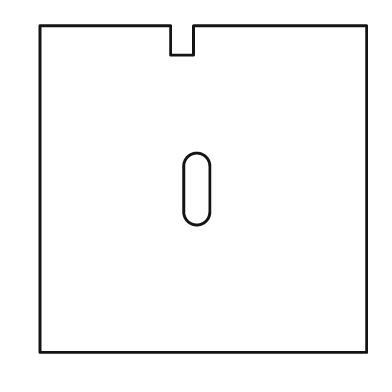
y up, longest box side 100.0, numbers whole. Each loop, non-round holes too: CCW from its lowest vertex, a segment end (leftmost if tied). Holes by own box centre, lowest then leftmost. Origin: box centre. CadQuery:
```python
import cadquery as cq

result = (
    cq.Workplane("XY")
    .moveTo(-50.0, -50.0)
    .lineTo(50.0, -50.0)
    .lineTo(50.0, 50.0)
    .lineTo(-3.0, 50.0)
    .lineTo(-3.0, 41.0)
    .lineTo(-10.0, 41.0)
    .lineTo(-10.0, 50.0)
    .lineTo(-50.0, 50.0)
    .close()
    .moveTo(-6.0, -7.0)
    .threePointArc((-2.0, -11.0), (2.0, -7.0))
    .lineTo(2.0, 7.0)
    .threePointArc((-2.0, 11.0), (-6.0, 7.0))
    .close()
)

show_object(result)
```